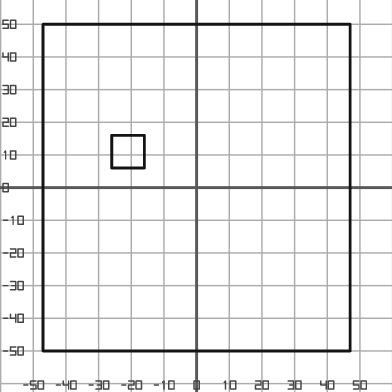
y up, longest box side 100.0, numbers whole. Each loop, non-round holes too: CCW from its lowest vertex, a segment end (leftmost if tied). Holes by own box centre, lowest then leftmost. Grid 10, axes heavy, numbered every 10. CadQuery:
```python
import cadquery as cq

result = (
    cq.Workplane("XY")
    .moveTo(-47.0, -50.0)
    .lineTo(47.0, -50.0)
    .lineTo(47.0, 50.0)
    .lineTo(-47.0, 50.0)
    .close()
    .moveTo(-26.0, 6.0)
    .lineTo(-16.0, 6.0)
    .lineTo(-16.0, 16.0)
    .lineTo(-26.0, 16.0)
    .close()
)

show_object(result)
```